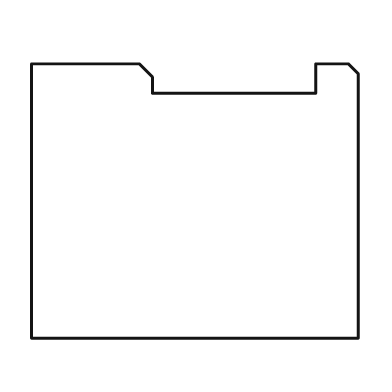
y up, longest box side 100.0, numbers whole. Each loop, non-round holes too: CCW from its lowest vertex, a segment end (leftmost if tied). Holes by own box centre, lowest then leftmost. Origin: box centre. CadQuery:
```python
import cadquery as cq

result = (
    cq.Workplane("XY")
    .moveTo(-50.0, -42.0)
    .lineTo(50.0, -42.0)
    .lineTo(50.0, 39.0)
    .lineTo(47.0, 42.0)
    .lineTo(37.0, 42.0)
    .lineTo(37.0, 33.0)
    .lineTo(-13.0, 33.0)
    .lineTo(-13.0, 38.0)
    .lineTo(-17.0, 42.0)
    .lineTo(-50.0, 42.0)
    .close()
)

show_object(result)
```